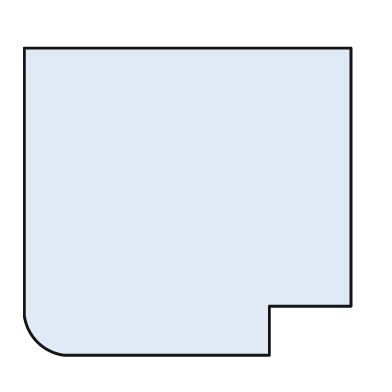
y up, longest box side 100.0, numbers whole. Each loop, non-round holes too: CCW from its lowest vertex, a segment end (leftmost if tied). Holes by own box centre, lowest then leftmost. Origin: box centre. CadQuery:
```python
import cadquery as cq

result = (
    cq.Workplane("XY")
    .moveTo(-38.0, -47.0)
    .lineTo(25.0, -47.0)
    .lineTo(25.0, -32.0)
    .lineTo(50.0, -32.0)
    .lineTo(50.0, 47.0)
    .lineTo(-50.0, 47.0)
    .lineTo(-50.0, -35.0)
    .threePointArc((-46.0, -43.0), (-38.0, -47.0))
    .close()
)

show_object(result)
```